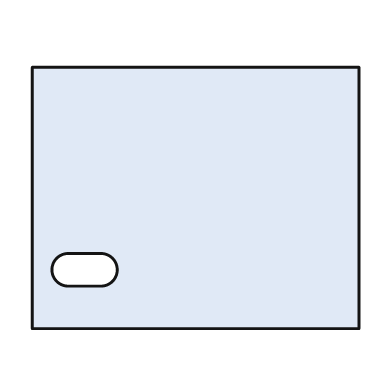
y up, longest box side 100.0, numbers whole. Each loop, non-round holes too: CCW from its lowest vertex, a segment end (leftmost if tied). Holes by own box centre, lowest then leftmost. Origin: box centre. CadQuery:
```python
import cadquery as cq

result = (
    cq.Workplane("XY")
    .moveTo(-50.0, -40.0)
    .lineTo(50.0, -40.0)
    .lineTo(50.0, 40.0)
    .lineTo(-50.0, 40.0)
    .close()
    .moveTo(-39.0, -27.0)
    .lineTo(-29.0, -27.0)
    .threePointArc((-24.0, -22.0), (-29.0, -17.0))
    .lineTo(-39.0, -17.0)
    .threePointArc((-44.0, -22.0), (-39.0, -27.0))
    .close()
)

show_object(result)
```